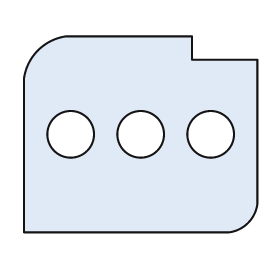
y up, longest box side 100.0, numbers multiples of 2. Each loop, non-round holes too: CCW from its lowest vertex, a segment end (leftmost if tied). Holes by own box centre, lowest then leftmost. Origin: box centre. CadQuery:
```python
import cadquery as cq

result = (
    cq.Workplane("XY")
    .moveTo(-50.0, -42.0)
    .lineTo(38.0, -42.0)
    .threePointArc((46.0, -38.0), (50.0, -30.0))
    .lineTo(50.0, 32.0)
    .lineTo(22.0, 32.0)
    .lineTo(22.0, 42.0)
    .lineTo(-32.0, 42.0)
    .threePointArc((-44.0, 36.0), (-50.0, 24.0))
    .close()
    .moveTo(-30.0, 0.0)
    .circle(10.0)
    .moveTo(0.0, 0.0)
    .circle(10.0)
    .moveTo(30.0, 0.0)
    .circle(10.0)
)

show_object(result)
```